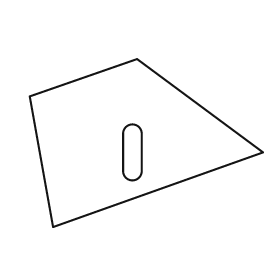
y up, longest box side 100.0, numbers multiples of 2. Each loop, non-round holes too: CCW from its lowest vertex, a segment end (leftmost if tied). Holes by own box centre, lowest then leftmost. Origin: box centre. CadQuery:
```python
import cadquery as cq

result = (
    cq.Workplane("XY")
    .moveTo(-40.0, -36.0)
    .lineTo(50.0, -4.0)
    .lineTo(-4.0, 36.0)
    .lineTo(-50.0, 20.0)
    .close()
    .moveTo(-10.0, -12.0)
    .threePointArc((-6.0, -16.0), (-2.0, -12.0))
    .lineTo(-2.0, 4.0)
    .threePointArc((-6.0, 8.0), (-10.0, 4.0))
    .close()
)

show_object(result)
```